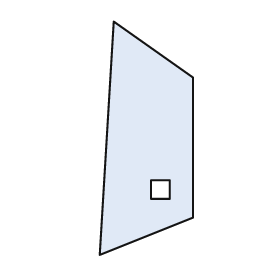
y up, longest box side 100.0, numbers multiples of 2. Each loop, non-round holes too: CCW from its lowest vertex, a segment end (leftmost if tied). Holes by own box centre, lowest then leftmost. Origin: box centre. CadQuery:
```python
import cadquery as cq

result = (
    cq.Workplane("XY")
    .moveTo(-20.0, -50.0)
    .lineTo(20.0, -34.0)
    .lineTo(20.0, 26.0)
    .lineTo(-14.0, 50.0)
    .close()
    .moveTo(2.0, -26.0)
    .lineTo(10.0, -26.0)
    .lineTo(10.0, -18.0)
    .lineTo(2.0, -18.0)
    .close()
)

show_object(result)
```